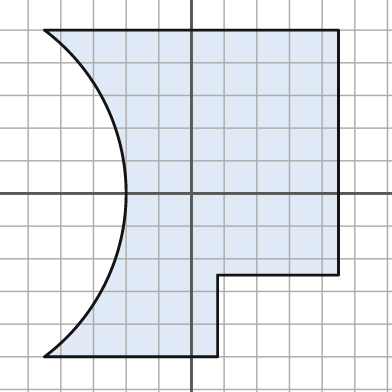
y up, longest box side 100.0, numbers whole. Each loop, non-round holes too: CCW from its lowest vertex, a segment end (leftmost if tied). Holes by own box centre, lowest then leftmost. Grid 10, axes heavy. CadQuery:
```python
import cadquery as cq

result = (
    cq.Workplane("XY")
    .moveTo(-45.0, -50.0)
    .lineTo(8.0, -50.0)
    .lineTo(8.0, -25.0)
    .lineTo(45.0, -25.0)
    .lineTo(45.0, 50.0)
    .lineTo(-45.0, 50.0)
    .threePointArc((-20.0, 0.0), (-45.0, -50.0))
    .close()
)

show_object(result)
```